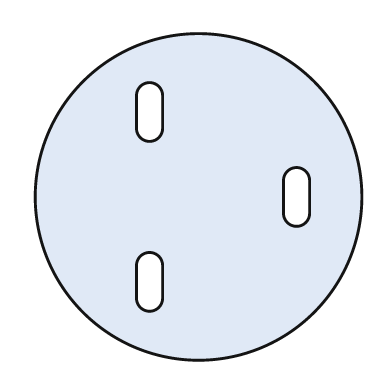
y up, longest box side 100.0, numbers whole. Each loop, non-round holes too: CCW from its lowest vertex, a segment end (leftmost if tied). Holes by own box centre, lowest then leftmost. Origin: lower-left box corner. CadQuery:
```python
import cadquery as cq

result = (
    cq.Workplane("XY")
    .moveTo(50.0, 50.0)
    .circle(50.0)
    .moveTo(31.0, 19.0)
    .threePointArc((35.0, 15.0), (39.0, 19.0))
    .lineTo(39.0, 29.0)
    .threePointArc((35.0, 33.0), (31.0, 29.0))
    .close()
    .moveTo(76.0, 45.0)
    .threePointArc((80.0, 41.0), (84.0, 45.0))
    .lineTo(84.0, 55.0)
    .threePointArc((80.0, 59.0), (76.0, 55.0))
    .close()
    .moveTo(31.0, 71.0)
    .threePointArc((35.0, 67.0), (39.0, 71.0))
    .lineTo(39.0, 81.0)
    .threePointArc((35.0, 85.0), (31.0, 81.0))
    .close()
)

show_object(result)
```